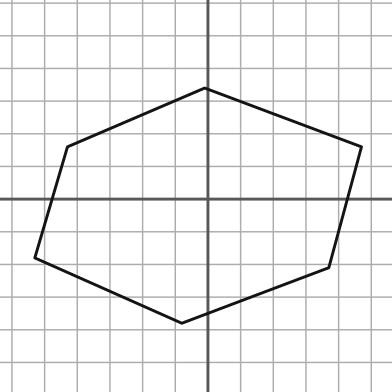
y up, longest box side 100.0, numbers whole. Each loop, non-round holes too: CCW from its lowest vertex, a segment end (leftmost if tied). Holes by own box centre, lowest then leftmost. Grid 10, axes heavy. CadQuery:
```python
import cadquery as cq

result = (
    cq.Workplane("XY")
    .moveTo(-8.0, -38.0)
    .lineTo(37.0, -21.0)
    .lineTo(47.0, 16.0)
    .lineTo(-1.0, 34.0)
    .lineTo(-43.0, 16.0)
    .lineTo(-53.0, -18.0)
    .close()
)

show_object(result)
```